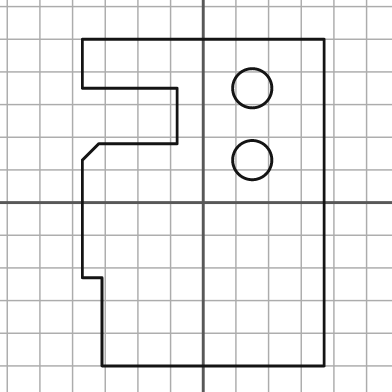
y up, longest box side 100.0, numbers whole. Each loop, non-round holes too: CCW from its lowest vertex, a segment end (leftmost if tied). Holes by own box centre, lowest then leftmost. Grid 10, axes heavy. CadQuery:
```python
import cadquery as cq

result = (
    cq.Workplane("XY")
    .moveTo(-31.0, -50.0)
    .lineTo(37.0, -50.0)
    .lineTo(37.0, 50.0)
    .lineTo(-37.0, 50.0)
    .lineTo(-37.0, 35.0)
    .lineTo(-8.0, 35.0)
    .lineTo(-8.0, 18.0)
    .lineTo(-32.0, 18.0)
    .lineTo(-37.0, 13.0)
    .lineTo(-37.0, -23.0)
    .lineTo(-31.0, -23.0)
    .close()
    .moveTo(15.0, 13.0)
    .circle(6.0)
    .moveTo(15.0, 35.0)
    .circle(6.0)
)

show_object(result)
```